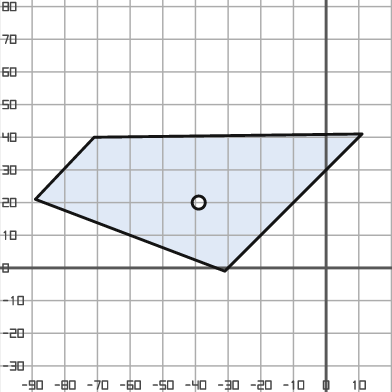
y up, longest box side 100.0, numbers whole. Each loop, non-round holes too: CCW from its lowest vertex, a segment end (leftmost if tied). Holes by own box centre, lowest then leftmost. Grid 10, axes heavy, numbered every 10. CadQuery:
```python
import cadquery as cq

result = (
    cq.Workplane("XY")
    .moveTo(-31.0, -1.0)
    .lineTo(11.0, 41.0)
    .lineTo(-71.0, 40.0)
    .lineTo(-89.0, 21.0)
    .close()
    .moveTo(-39.0, 20.0)
    .circle(2.0)
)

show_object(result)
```